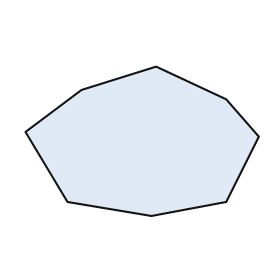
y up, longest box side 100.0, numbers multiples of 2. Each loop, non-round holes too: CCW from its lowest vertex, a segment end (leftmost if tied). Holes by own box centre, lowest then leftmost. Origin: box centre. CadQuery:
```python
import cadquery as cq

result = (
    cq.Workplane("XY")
    .moveTo(4.0, -32.0)
    .lineTo(36.0, -26.0)
    .lineTo(50.0, 2.0)
    .lineTo(36.0, 18.0)
    .lineTo(6.0, 32.0)
    .lineTo(-26.0, 22.0)
    .lineTo(-50.0, 4.0)
    .lineTo(-32.0, -26.0)
    .close()
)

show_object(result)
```